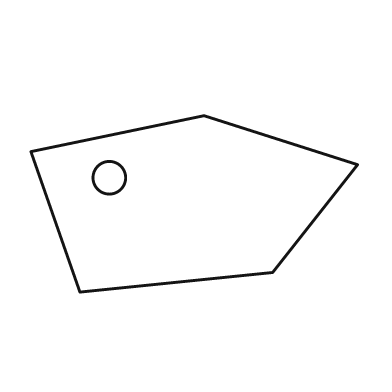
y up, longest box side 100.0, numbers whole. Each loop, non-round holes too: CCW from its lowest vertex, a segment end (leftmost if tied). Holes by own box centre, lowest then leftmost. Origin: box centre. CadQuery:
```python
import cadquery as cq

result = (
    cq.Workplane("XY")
    .moveTo(-35.0, -27.0)
    .lineTo(24.0, -21.0)
    .lineTo(50.0, 12.0)
    .lineTo(3.0, 27.0)
    .lineTo(-50.0, 16.0)
    .close()
    .moveTo(-26.0, 8.0)
    .circle(5.0)
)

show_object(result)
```